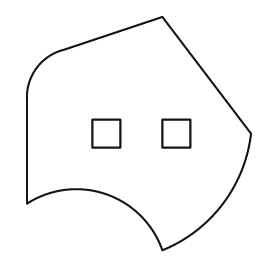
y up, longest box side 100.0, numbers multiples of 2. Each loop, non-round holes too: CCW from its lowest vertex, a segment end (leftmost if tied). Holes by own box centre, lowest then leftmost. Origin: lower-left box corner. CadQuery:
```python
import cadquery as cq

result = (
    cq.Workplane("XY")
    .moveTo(58.0, 0.0)
    .threePointArc((84.0, 20.0), (96.0, 50.0))
    .lineTo(58.0, 100.0)
    .lineTo(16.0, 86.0)
    .threePointArc((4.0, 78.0), (0.0, 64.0))
    .lineTo(0.0, 20.0)
    .threePointArc((34.0, 24.0), (58.0, 0.0))
    .close()
    .moveTo(28.0, 44.0)
    .lineTo(40.0, 44.0)
    .lineTo(40.0, 56.0)
    .lineTo(28.0, 56.0)
    .close()
    .moveTo(58.0, 44.0)
    .lineTo(70.0, 44.0)
    .lineTo(70.0, 56.0)
    .lineTo(58.0, 56.0)
    .close()
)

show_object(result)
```